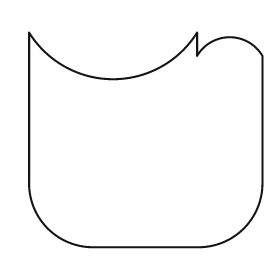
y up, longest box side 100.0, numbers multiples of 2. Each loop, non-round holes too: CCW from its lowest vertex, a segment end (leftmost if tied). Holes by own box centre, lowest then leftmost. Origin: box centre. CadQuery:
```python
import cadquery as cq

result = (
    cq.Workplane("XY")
    .moveTo(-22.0, -46.0)
    .lineTo(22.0, -46.0)
    .threePointArc((42.0, -38.0), (50.0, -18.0))
    .lineTo(50.0, 36.0)
    .threePointArc((36.0, 44.0), (22.0, 36.0))
    .lineTo(22.0, 46.0)
    .threePointArc((-14.0, 26.0), (-50.0, 46.0))
    .lineTo(-50.0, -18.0)
    .threePointArc((-42.0, -38.0), (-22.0, -46.0))
    .close()
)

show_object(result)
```